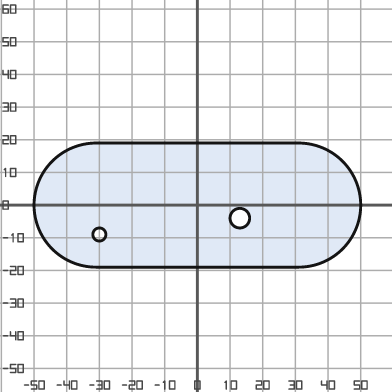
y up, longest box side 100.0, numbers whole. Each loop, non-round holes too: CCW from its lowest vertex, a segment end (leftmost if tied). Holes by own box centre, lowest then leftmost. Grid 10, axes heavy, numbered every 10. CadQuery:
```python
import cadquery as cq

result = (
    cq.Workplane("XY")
    .moveTo(-31.0, -19.0)
    .lineTo(31.0, -19.0)
    .threePointArc((50.0, 0.0), (31.0, 19.0))
    .lineTo(-31.0, 19.0)
    .threePointArc((-50.0, 0.0), (-31.0, -19.0))
    .close()
    .moveTo(-30.0, -9.0)
    .circle(2.0)
    .moveTo(13.0, -4.0)
    .circle(3.0)
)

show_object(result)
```